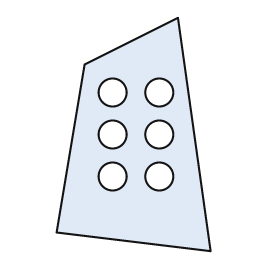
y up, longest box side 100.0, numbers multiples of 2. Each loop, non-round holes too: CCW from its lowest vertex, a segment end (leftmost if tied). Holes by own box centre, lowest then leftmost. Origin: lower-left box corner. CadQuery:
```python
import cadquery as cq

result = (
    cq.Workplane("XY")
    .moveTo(66.0, 0.0)
    .lineTo(52.0, 100.0)
    .lineTo(12.0, 80.0)
    .lineTo(0.0, 8.0)
    .close()
    .moveTo(24.0, 32.0)
    .circle(6.0)
    .moveTo(44.0, 32.0)
    .circle(6.0)
    .moveTo(24.0, 50.0)
    .circle(6.0)
    .moveTo(44.0, 50.0)
    .circle(6.0)
    .moveTo(24.0, 68.0)
    .circle(6.0)
    .moveTo(44.0, 68.0)
    .circle(6.0)
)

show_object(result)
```